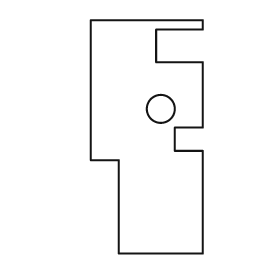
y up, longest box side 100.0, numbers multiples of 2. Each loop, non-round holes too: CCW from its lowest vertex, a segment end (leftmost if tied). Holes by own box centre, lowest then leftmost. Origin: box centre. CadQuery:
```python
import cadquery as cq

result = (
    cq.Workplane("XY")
    .moveTo(-12.0, -50.0)
    .lineTo(24.0, -50.0)
    .lineTo(24.0, -6.0)
    .lineTo(12.0, -6.0)
    .lineTo(12.0, 4.0)
    .lineTo(24.0, 4.0)
    .lineTo(24.0, 32.0)
    .lineTo(4.0, 32.0)
    .lineTo(4.0, 46.0)
    .lineTo(24.0, 46.0)
    .lineTo(24.0, 50.0)
    .lineTo(-24.0, 50.0)
    .lineTo(-24.0, -10.0)
    .lineTo(-12.0, -10.0)
    .close()
    .moveTo(6.0, 12.0)
    .circle(6.0)
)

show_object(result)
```